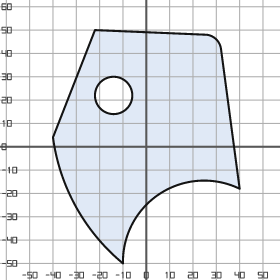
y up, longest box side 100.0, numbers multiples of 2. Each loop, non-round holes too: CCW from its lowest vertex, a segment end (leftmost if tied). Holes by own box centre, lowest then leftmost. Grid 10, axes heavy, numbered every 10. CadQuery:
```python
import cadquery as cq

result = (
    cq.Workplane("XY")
    .moveTo(-10.0, -50.0)
    .threePointArc((6.0, -20.0), (40.0, -18.0))
    .lineTo(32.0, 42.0)
    .threePointArc((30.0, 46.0), (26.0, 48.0))
    .lineTo(-22.0, 50.0)
    .lineTo(-40.0, 4.0)
    .threePointArc((-30.0, -26.0), (-10.0, -50.0))
    .close()
    .moveTo(-14.0, 22.0)
    .circle(8.0)
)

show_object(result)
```